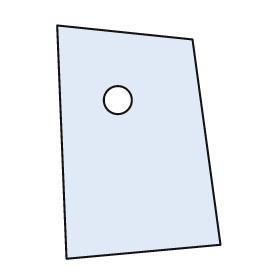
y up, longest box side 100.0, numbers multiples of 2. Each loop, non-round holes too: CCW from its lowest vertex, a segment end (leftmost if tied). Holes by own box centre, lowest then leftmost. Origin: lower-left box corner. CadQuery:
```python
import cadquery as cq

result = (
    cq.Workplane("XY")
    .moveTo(4.0, 0.0)
    .lineTo(70.0, 6.0)
    .lineTo(58.0, 94.0)
    .lineTo(0.0, 100.0)
    .close()
    .moveTo(26.0, 68.0)
    .circle(6.0)
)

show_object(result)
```